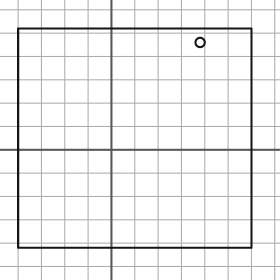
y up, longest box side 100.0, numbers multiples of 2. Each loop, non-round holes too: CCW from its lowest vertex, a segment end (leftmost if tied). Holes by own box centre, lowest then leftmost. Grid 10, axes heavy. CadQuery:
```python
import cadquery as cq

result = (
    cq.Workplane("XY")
    .moveTo(-40.0, -42.0)
    .lineTo(60.0, -42.0)
    .lineTo(60.0, 52.0)
    .lineTo(-40.0, 52.0)
    .close()
    .moveTo(38.0, 46.0)
    .circle(2.0)
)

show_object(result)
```